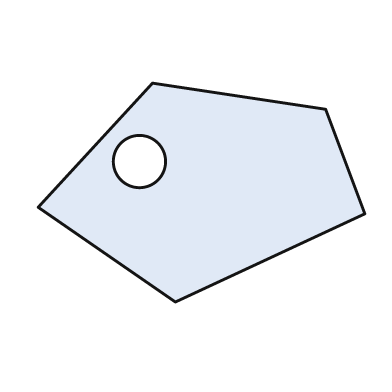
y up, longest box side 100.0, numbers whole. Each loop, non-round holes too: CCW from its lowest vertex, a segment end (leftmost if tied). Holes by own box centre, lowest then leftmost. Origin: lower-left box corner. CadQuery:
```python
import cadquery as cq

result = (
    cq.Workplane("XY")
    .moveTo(42.0, 0.0)
    .lineTo(100.0, 27.0)
    .lineTo(88.0, 59.0)
    .lineTo(35.0, 67.0)
    .lineTo(0.0, 29.0)
    .close()
    .moveTo(31.0, 43.0)
    .circle(8.0)
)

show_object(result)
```